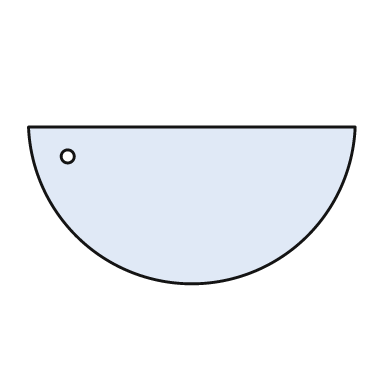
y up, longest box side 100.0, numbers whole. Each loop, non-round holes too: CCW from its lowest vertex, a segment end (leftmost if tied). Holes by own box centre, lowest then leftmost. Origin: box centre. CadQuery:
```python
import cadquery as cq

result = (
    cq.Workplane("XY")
    .moveTo(-50.0, 24.0)
    .threePointArc((0.0, -24.0), (50.0, 24.0))
    .close()
    .moveTo(-38.0, 15.0)
    .circle(2.0)
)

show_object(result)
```